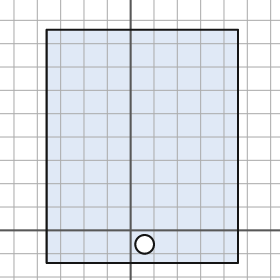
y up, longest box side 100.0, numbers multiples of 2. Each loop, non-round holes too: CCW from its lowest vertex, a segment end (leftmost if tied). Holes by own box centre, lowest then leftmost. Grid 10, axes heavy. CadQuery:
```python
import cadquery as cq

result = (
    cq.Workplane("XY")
    .moveTo(-36.0, -14.0)
    .lineTo(46.0, -14.0)
    .lineTo(46.0, 86.0)
    .lineTo(-36.0, 86.0)
    .close()
    .moveTo(6.0, -6.0)
    .circle(4.0)
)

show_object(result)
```